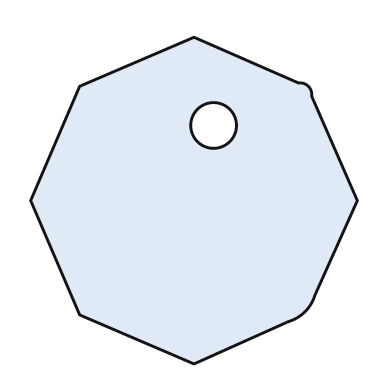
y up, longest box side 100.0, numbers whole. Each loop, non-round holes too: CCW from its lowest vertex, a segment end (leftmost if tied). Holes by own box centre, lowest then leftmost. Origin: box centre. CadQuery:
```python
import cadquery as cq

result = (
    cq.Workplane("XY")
    .moveTo(0.0, -50.0)
    .lineTo(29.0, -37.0)
    .threePointArc((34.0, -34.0), (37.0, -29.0))
    .lineTo(50.0, 0.0)
    .lineTo(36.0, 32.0)
    .threePointArc((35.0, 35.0), (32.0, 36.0))
    .lineTo(0.0, 50.0)
    .lineTo(-35.0, 35.0)
    .lineTo(-50.0, 0.0)
    .lineTo(-35.0, -35.0)
    .close()
    .moveTo(6.0, 23.0)
    .circle(7.0)
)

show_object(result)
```